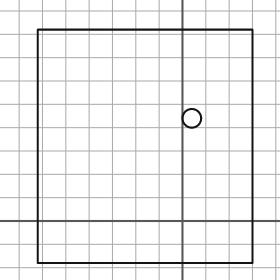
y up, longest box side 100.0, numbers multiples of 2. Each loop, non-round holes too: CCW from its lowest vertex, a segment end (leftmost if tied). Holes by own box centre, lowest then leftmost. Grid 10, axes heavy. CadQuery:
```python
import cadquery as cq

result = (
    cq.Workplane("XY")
    .moveTo(-62.0, -18.0)
    .lineTo(30.0, -18.0)
    .lineTo(30.0, 82.0)
    .lineTo(-62.0, 82.0)
    .close()
    .moveTo(4.0, 44.0)
    .circle(4.0)
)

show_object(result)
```